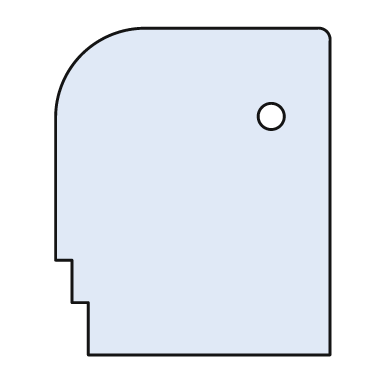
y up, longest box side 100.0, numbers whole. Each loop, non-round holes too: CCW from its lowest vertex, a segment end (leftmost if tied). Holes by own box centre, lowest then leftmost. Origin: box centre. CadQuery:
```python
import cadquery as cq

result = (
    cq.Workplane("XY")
    .moveTo(-32.0, -50.0)
    .lineTo(42.0, -50.0)
    .lineTo(42.0, 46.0)
    .threePointArc((41.0, 49.0), (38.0, 50.0))
    .lineTo(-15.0, 50.0)
    .threePointArc((-34.0, 42.0), (-42.0, 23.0))
    .lineTo(-42.0, -21.0)
    .lineTo(-37.0, -21.0)
    .lineTo(-37.0, -34.0)
    .lineTo(-32.0, -34.0)
    .close()
    .moveTo(24.0, 23.0)
    .circle(4.0)
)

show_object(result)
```